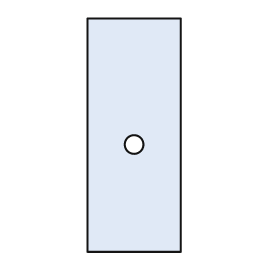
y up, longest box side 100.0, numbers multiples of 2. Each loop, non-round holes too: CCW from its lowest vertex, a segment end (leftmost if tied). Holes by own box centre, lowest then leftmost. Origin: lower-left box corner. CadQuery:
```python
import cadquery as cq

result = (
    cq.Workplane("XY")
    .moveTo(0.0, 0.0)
    .lineTo(40.0, 0.0)
    .lineTo(40.0, 100.0)
    .lineTo(0.0, 100.0)
    .close()
    .moveTo(20.0, 46.0)
    .circle(4.0)
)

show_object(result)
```